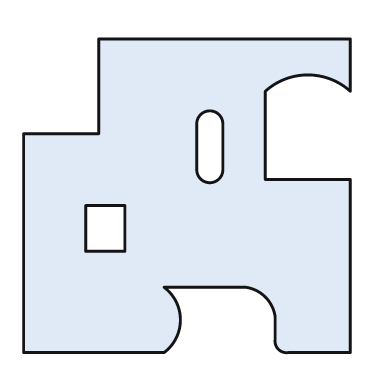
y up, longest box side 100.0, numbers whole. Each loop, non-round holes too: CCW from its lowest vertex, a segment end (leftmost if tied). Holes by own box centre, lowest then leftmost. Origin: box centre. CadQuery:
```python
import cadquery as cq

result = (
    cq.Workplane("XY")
    .moveTo(-50.0, -48.0)
    .lineTo(-7.0, -48.0)
    .threePointArc((-2.0, -38.0), (-7.0, -28.0))
    .lineTo(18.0, -28.0)
    .threePointArc((24.0, -31.0), (27.0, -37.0))
    .lineTo(27.0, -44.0)
    .threePointArc((28.0, -47.0), (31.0, -48.0))
    .lineTo(50.0, -48.0)
    .lineTo(50.0, 5.0)
    .lineTo(24.0, 5.0)
    .lineTo(24.0, 32.0)
    .threePointArc((37.0, 37.0), (50.0, 32.0))
    .lineTo(50.0, 48.0)
    .lineTo(-27.0, 48.0)
    .lineTo(-27.0, 19.0)
    .lineTo(-50.0, 19.0)
    .close()
    .moveTo(-31.0, -17.0)
    .lineTo(-19.0, -17.0)
    .lineTo(-19.0, -3.0)
    .lineTo(-31.0, -3.0)
    .close()
    .moveTo(3.0, 8.0)
    .threePointArc((7.0, 4.0), (11.0, 8.0))
    .lineTo(11.0, 22.0)
    .threePointArc((7.0, 26.0), (3.0, 22.0))
    .close()
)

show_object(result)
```